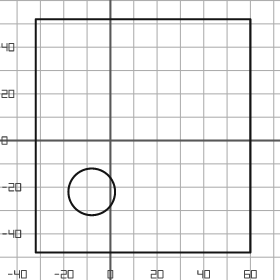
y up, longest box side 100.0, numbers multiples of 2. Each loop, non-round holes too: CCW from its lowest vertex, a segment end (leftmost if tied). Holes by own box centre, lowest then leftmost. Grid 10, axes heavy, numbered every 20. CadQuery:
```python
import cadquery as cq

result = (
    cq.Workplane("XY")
    .moveTo(-32.0, -48.0)
    .lineTo(60.0, -48.0)
    .lineTo(60.0, 52.0)
    .lineTo(-32.0, 52.0)
    .close()
    .moveTo(-8.0, -22.0)
    .circle(10.0)
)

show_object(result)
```